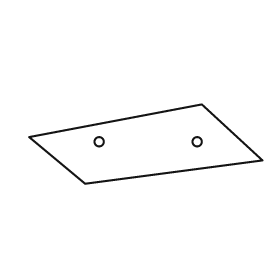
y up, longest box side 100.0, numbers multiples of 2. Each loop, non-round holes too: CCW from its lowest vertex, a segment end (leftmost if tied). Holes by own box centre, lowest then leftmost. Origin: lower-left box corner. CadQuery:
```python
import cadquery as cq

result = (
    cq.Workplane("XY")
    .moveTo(24.0, 0.0)
    .lineTo(100.0, 10.0)
    .lineTo(74.0, 34.0)
    .lineTo(0.0, 20.0)
    .close()
    .moveTo(30.0, 18.0)
    .circle(2.0)
    .moveTo(72.0, 18.0)
    .circle(2.0)
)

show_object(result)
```